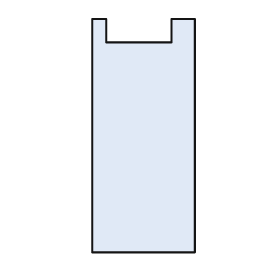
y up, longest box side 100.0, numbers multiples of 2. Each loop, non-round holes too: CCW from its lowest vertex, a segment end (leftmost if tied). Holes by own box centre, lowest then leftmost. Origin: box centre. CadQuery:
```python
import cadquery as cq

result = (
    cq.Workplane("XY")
    .moveTo(-22.0, -50.0)
    .lineTo(22.0, -50.0)
    .lineTo(22.0, 50.0)
    .lineTo(12.0, 50.0)
    .lineTo(12.0, 40.0)
    .lineTo(-16.0, 40.0)
    .lineTo(-16.0, 50.0)
    .lineTo(-22.0, 50.0)
    .close()
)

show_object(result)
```